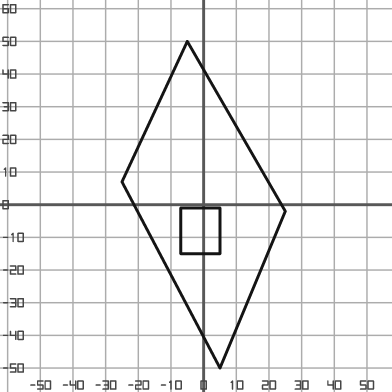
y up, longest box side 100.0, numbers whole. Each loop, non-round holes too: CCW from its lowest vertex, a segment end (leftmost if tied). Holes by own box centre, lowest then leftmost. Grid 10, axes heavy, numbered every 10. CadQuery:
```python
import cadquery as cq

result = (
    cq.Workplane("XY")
    .moveTo(5.0, -50.0)
    .lineTo(25.0, -2.0)
    .lineTo(-5.0, 50.0)
    .lineTo(-25.0, 7.0)
    .close()
    .moveTo(-7.0, -15.0)
    .lineTo(5.0, -15.0)
    .lineTo(5.0, -1.0)
    .lineTo(-7.0, -1.0)
    .close()
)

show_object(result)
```